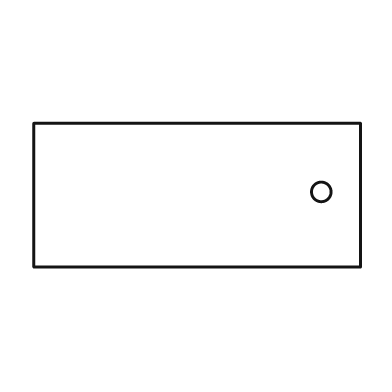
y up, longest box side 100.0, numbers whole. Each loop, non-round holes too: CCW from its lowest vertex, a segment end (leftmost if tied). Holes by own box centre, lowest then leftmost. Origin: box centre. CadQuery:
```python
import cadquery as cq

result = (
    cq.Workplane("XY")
    .moveTo(-50.0, -22.0)
    .lineTo(50.0, -22.0)
    .lineTo(50.0, 22.0)
    .lineTo(-50.0, 22.0)
    .close()
    .moveTo(38.0, 1.0)
    .circle(3.0)
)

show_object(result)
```